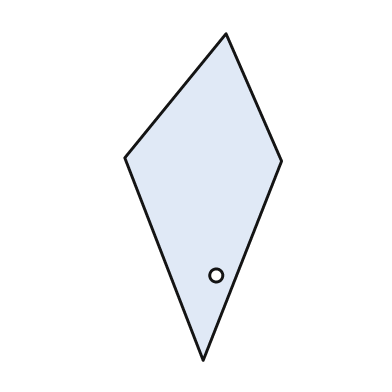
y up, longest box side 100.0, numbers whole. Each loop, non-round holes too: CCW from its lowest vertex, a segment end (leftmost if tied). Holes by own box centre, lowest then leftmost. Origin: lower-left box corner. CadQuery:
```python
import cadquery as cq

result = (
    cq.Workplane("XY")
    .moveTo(24.0, 0.0)
    .lineTo(48.0, 61.0)
    .lineTo(31.0, 100.0)
    .lineTo(0.0, 62.0)
    .close()
    .moveTo(28.0, 26.0)
    .circle(2.0)
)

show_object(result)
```